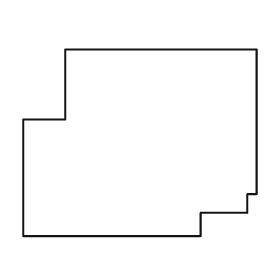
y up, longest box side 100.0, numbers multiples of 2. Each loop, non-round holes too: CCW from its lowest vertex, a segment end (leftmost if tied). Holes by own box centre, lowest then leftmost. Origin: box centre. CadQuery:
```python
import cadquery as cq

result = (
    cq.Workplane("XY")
    .moveTo(-50.0, -40.0)
    .lineTo(26.0, -40.0)
    .lineTo(26.0, -30.0)
    .lineTo(46.0, -30.0)
    .lineTo(46.0, -22.0)
    .lineTo(50.0, -22.0)
    .lineTo(50.0, 40.0)
    .lineTo(-32.0, 40.0)
    .lineTo(-32.0, 10.0)
    .lineTo(-50.0, 10.0)
    .close()
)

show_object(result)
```